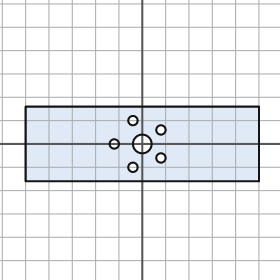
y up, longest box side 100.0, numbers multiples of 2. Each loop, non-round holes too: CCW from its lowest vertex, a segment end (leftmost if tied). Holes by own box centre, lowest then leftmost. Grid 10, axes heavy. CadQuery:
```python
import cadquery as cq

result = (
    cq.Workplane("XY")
    .moveTo(-50.0, -16.0)
    .lineTo(50.0, -16.0)
    .lineTo(50.0, 16.0)
    .lineTo(-50.0, 16.0)
    .close()
    .moveTo(-4.0, -10.0)
    .circle(2.0)
    .moveTo(8.0, -6.0)
    .circle(2.0)
    .moveTo(-12.0, 0.0)
    .circle(2.0)
    .moveTo(0.0, 0.0)
    .circle(4.0)
    .moveTo(8.0, 6.0)
    .circle(2.0)
    .moveTo(-4.0, 10.0)
    .circle(2.0)
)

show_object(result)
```